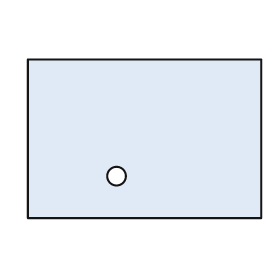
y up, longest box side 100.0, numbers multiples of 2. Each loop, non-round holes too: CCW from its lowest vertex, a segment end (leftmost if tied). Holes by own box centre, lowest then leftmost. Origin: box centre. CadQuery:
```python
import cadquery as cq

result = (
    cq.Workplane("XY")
    .moveTo(-50.0, -34.0)
    .lineTo(50.0, -34.0)
    .lineTo(50.0, 34.0)
    .lineTo(-50.0, 34.0)
    .close()
    .moveTo(-12.0, -16.0)
    .circle(4.0)
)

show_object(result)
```